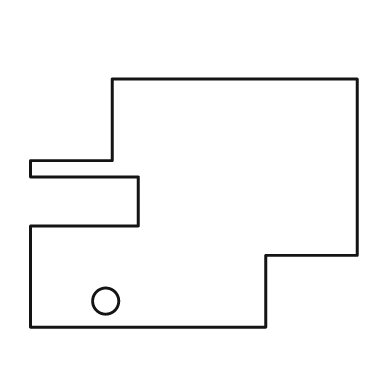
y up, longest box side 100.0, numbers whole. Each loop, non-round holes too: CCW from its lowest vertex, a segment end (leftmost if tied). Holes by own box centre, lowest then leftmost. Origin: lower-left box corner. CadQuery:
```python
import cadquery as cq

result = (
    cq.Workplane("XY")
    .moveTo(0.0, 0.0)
    .lineTo(72.0, 0.0)
    .lineTo(72.0, 22.0)
    .lineTo(100.0, 22.0)
    .lineTo(100.0, 76.0)
    .lineTo(25.0, 76.0)
    .lineTo(25.0, 51.0)
    .lineTo(0.0, 51.0)
    .lineTo(0.0, 46.0)
    .lineTo(33.0, 46.0)
    .lineTo(33.0, 31.0)
    .lineTo(0.0, 31.0)
    .close()
    .moveTo(23.0, 8.0)
    .circle(4.0)
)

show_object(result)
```